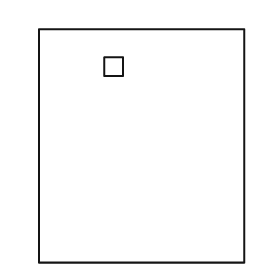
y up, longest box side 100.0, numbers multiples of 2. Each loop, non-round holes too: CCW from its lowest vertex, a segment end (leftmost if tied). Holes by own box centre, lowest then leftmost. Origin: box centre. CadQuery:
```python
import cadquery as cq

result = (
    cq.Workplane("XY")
    .moveTo(-44.0, -50.0)
    .lineTo(44.0, -50.0)
    .lineTo(44.0, 50.0)
    .lineTo(-44.0, 50.0)
    .close()
    .moveTo(-16.0, 30.0)
    .lineTo(-8.0, 30.0)
    .lineTo(-8.0, 38.0)
    .lineTo(-16.0, 38.0)
    .close()
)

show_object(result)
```